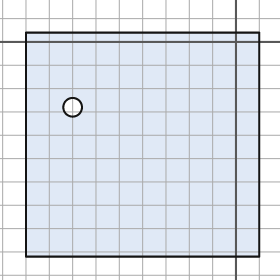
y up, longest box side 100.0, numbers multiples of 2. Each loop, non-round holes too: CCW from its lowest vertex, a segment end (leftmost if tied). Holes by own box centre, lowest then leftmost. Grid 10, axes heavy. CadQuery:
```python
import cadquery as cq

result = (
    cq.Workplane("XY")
    .moveTo(-90.0, -92.0)
    .lineTo(10.0, -92.0)
    .lineTo(10.0, 4.0)
    .lineTo(-90.0, 4.0)
    .close()
    .moveTo(-70.0, -28.0)
    .circle(4.0)
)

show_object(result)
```